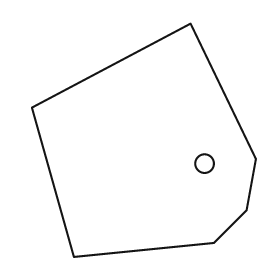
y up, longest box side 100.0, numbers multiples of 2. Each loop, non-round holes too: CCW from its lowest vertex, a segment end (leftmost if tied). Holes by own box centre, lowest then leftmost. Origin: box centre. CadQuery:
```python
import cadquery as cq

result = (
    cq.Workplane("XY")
    .moveTo(-30.0, -50.0)
    .lineTo(30.0, -44.0)
    .lineTo(44.0, -30.0)
    .lineTo(48.0, -8.0)
    .lineTo(20.0, 50.0)
    .lineTo(-48.0, 14.0)
    .close()
    .moveTo(26.0, -10.0)
    .circle(4.0)
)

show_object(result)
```